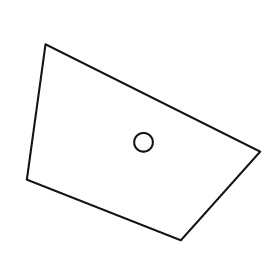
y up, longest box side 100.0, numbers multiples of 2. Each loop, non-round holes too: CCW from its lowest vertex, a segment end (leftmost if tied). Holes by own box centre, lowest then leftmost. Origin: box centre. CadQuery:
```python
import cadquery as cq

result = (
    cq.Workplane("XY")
    .moveTo(16.0, -42.0)
    .lineTo(50.0, -4.0)
    .lineTo(-42.0, 42.0)
    .lineTo(-50.0, -16.0)
    .close()
    .moveTo(0.0, 0.0)
    .circle(4.0)
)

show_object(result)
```